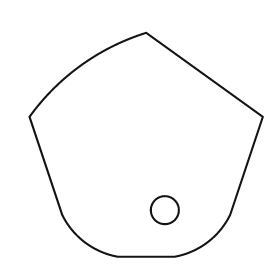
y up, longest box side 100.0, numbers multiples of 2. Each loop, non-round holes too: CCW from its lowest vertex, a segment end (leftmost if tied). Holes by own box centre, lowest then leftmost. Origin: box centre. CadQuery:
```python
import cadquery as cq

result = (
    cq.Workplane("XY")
    .moveTo(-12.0, -48.0)
    .lineTo(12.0, -48.0)
    .threePointArc((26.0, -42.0), (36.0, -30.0))
    .lineTo(50.0, 12.0)
    .lineTo(0.0, 48.0)
    .threePointArc((-28.0, 34.0), (-50.0, 12.0))
    .lineTo(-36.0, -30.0)
    .threePointArc((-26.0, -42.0), (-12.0, -48.0))
    .close()
    .moveTo(8.0, -28.0)
    .circle(6.0)
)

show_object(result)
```